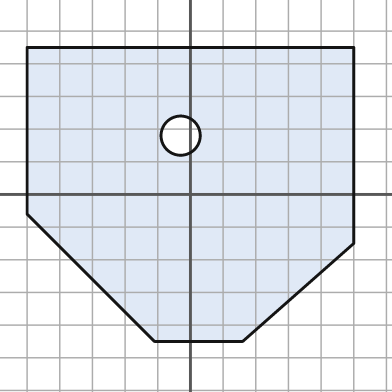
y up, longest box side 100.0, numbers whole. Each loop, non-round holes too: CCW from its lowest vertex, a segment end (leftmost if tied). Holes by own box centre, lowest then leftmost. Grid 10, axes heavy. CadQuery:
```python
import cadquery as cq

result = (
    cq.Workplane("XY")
    .moveTo(-11.0, -45.0)
    .lineTo(16.0, -45.0)
    .lineTo(50.0, -15.0)
    .lineTo(50.0, 45.0)
    .lineTo(-50.0, 45.0)
    .lineTo(-50.0, -6.0)
    .close()
    .moveTo(-3.0, 18.0)
    .circle(6.0)
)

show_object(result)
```